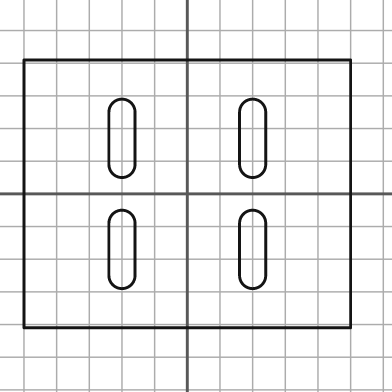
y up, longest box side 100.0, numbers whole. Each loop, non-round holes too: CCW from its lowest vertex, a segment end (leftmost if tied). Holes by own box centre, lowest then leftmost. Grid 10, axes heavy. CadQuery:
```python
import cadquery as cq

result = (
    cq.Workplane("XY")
    .moveTo(-50.0, -41.0)
    .lineTo(50.0, -41.0)
    .lineTo(50.0, 41.0)
    .lineTo(-50.0, 41.0)
    .close()
    .moveTo(-24.0, -25.0)
    .threePointArc((-20.0, -29.0), (-16.0, -25.0))
    .lineTo(-16.0, -9.0)
    .threePointArc((-20.0, -5.0), (-24.0, -9.0))
    .close()
    .moveTo(16.0, -25.0)
    .threePointArc((20.0, -29.0), (24.0, -25.0))
    .lineTo(24.0, -9.0)
    .threePointArc((20.0, -5.0), (16.0, -9.0))
    .close()
    .moveTo(-24.0, 9.0)
    .threePointArc((-20.0, 5.0), (-16.0, 9.0))
    .lineTo(-16.0, 25.0)
    .threePointArc((-20.0, 29.0), (-24.0, 25.0))
    .close()
    .moveTo(16.0, 9.0)
    .threePointArc((20.0, 5.0), (24.0, 9.0))
    .lineTo(24.0, 25.0)
    .threePointArc((20.0, 29.0), (16.0, 25.0))
    .close()
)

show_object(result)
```